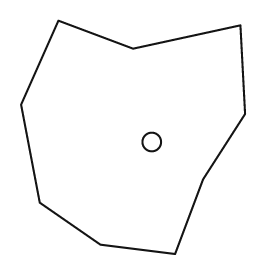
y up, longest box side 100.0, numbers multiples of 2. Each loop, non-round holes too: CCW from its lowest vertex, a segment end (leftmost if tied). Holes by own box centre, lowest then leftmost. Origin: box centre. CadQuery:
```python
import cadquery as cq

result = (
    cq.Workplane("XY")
    .moveTo(18.0, -50.0)
    .lineTo(30.0, -18.0)
    .lineTo(48.0, 10.0)
    .lineTo(46.0, 48.0)
    .lineTo(0.0, 38.0)
    .lineTo(-32.0, 50.0)
    .lineTo(-48.0, 14.0)
    .lineTo(-40.0, -28.0)
    .lineTo(-14.0, -46.0)
    .close()
    .moveTo(8.0, -2.0)
    .circle(4.0)
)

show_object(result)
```